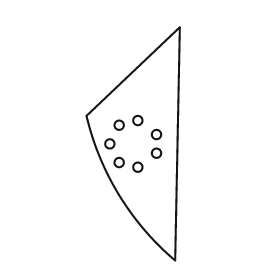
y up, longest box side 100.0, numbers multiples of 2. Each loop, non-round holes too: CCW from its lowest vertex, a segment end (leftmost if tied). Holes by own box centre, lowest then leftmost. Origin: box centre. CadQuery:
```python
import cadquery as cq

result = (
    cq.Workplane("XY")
    .moveTo(18.0, -50.0)
    .lineTo(20.0, 50.0)
    .lineTo(-20.0, 12.0)
    .threePointArc((-6.0, -22.0), (18.0, -50.0))
    .close()
    .moveTo(2.0, -10.0)
    .circle(2.0)
    .moveTo(-6.0, -8.0)
    .circle(2.0)
    .moveTo(10.0, -4.0)
    .circle(2.0)
    .moveTo(-10.0, 0.0)
    .circle(2.0)
    .moveTo(10.0, 4.0)
    .circle(2.0)
    .moveTo(-6.0, 8.0)
    .circle(2.0)
    .moveTo(2.0, 10.0)
    .circle(2.0)
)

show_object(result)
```